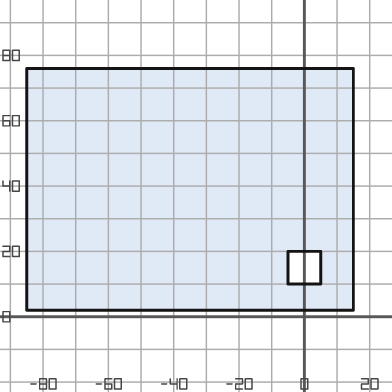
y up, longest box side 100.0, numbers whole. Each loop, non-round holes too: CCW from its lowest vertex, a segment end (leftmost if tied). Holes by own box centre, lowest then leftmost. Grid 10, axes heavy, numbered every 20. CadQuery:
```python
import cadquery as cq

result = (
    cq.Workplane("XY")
    .moveTo(-85.0, 2.0)
    .lineTo(15.0, 2.0)
    .lineTo(15.0, 76.0)
    .lineTo(-85.0, 76.0)
    .close()
    .moveTo(-5.0, 10.0)
    .lineTo(5.0, 10.0)
    .lineTo(5.0, 20.0)
    .lineTo(-5.0, 20.0)
    .close()
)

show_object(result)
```